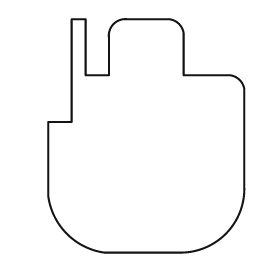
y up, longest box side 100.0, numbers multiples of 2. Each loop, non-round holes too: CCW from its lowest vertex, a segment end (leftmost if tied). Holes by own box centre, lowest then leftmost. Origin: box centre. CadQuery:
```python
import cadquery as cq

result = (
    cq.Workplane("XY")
    .moveTo(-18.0, -50.0)
    .lineTo(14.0, -50.0)
    .threePointArc((34.0, -42.0), (42.0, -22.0))
    .lineTo(42.0, 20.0)
    .threePointArc((40.0, 24.0), (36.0, 26.0))
    .lineTo(16.0, 26.0)
    .lineTo(16.0, 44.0)
    .threePointArc((14.0, 48.0), (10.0, 50.0))
    .lineTo(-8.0, 50.0)
    .threePointArc((-14.0, 48.0), (-16.0, 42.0))
    .lineTo(-16.0, 26.0)
    .lineTo(-26.0, 26.0)
    .lineTo(-26.0, 50.0)
    .lineTo(-32.0, 50.0)
    .lineTo(-32.0, 6.0)
    .lineTo(-42.0, 6.0)
    .lineTo(-42.0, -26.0)
    .threePointArc((-34.0, -42.0), (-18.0, -50.0))
    .close()
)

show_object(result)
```